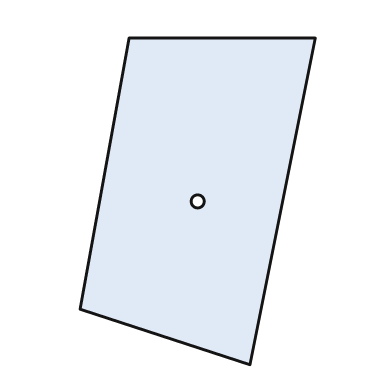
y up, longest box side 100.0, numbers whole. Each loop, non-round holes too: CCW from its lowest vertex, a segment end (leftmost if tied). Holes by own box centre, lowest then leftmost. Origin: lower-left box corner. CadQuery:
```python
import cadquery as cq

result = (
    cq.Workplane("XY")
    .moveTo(52.0, 0.0)
    .lineTo(72.0, 100.0)
    .lineTo(15.0, 100.0)
    .lineTo(0.0, 17.0)
    .close()
    .moveTo(36.0, 50.0)
    .circle(2.0)
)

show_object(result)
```